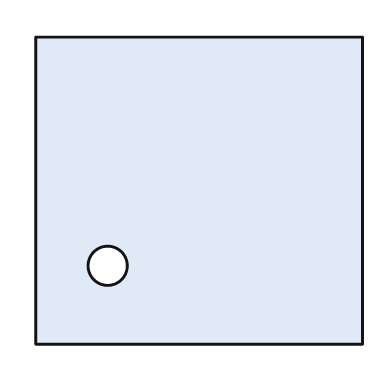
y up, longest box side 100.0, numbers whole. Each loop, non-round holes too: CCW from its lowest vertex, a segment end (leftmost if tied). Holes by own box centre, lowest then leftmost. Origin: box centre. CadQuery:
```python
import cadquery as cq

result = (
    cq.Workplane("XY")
    .moveTo(-50.0, -47.0)
    .lineTo(50.0, -47.0)
    .lineTo(50.0, 47.0)
    .lineTo(-50.0, 47.0)
    .close()
    .moveTo(-28.0, -23.0)
    .circle(6.0)
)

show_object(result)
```